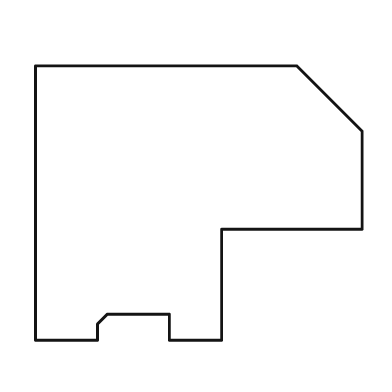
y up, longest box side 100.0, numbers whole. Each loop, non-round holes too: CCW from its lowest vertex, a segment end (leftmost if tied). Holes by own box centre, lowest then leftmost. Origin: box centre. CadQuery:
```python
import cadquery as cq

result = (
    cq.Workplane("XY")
    .moveTo(-50.0, -42.0)
    .lineTo(-31.0, -42.0)
    .lineTo(-31.0, -37.0)
    .lineTo(-28.0, -34.0)
    .lineTo(-9.0, -34.0)
    .lineTo(-9.0, -42.0)
    .lineTo(7.0, -42.0)
    .lineTo(7.0, -8.0)
    .lineTo(50.0, -8.0)
    .lineTo(50.0, 22.0)
    .lineTo(30.0, 42.0)
    .lineTo(-50.0, 42.0)
    .close()
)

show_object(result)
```